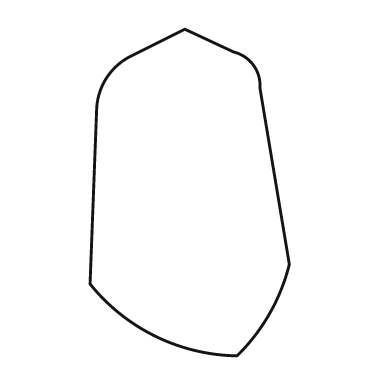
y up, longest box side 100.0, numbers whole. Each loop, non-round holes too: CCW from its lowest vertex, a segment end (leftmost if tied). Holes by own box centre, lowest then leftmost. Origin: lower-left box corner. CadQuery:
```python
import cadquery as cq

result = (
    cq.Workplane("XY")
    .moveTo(45.0, 0.0)
    .threePointArc((55.0, 13.0), (61.0, 28.0))
    .lineTo(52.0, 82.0)
    .threePointArc((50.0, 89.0), (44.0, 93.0))
    .lineTo(29.0, 100.0)
    .lineTo(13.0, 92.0)
    .threePointArc((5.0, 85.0), (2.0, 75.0))
    .lineTo(0.0, 22.0)
    .threePointArc((20.0, 6.0), (45.0, 0.0))
    .close()
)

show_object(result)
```